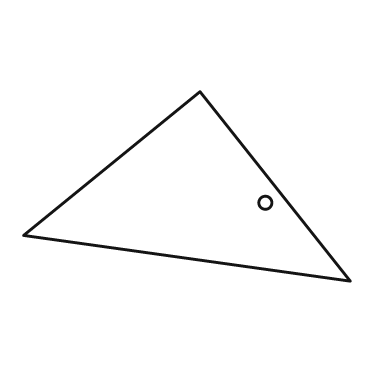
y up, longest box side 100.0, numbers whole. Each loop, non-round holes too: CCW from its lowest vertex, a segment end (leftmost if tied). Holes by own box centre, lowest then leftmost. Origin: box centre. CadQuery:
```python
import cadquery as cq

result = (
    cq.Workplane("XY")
    .moveTo(50.0, -29.0)
    .lineTo(4.0, 29.0)
    .lineTo(-50.0, -15.0)
    .close()
    .moveTo(24.0, -5.0)
    .circle(2.0)
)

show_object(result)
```